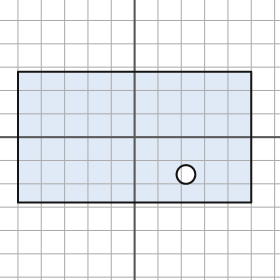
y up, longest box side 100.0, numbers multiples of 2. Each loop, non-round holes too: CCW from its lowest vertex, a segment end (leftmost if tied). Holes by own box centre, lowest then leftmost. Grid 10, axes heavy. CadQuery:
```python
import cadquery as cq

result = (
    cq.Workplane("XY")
    .moveTo(-50.0, -28.0)
    .lineTo(50.0, -28.0)
    .lineTo(50.0, 28.0)
    .lineTo(-50.0, 28.0)
    .close()
    .moveTo(22.0, -16.0)
    .circle(4.0)
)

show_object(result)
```